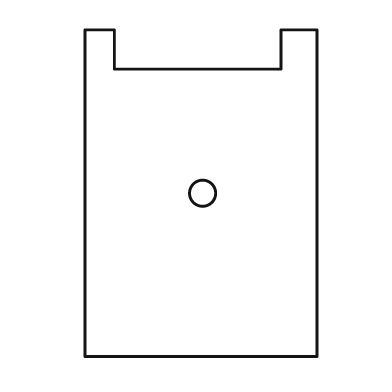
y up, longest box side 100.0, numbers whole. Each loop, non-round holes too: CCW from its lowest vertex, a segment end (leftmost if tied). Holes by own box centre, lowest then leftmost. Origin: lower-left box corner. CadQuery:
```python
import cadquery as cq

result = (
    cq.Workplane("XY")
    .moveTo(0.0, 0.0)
    .lineTo(71.0, 0.0)
    .lineTo(71.0, 100.0)
    .lineTo(60.0, 100.0)
    .lineTo(60.0, 88.0)
    .lineTo(9.0, 88.0)
    .lineTo(9.0, 100.0)
    .lineTo(0.0, 100.0)
    .close()
    .moveTo(36.0, 50.0)
    .circle(4.0)
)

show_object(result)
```